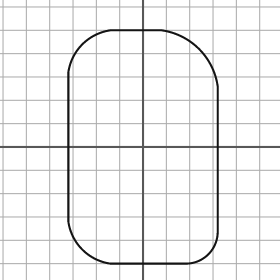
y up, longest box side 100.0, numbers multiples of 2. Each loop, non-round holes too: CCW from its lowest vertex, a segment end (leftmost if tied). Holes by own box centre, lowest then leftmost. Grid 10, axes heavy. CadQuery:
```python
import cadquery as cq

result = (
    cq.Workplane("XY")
    .moveTo(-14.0, -50.0)
    .lineTo(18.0, -50.0)
    .threePointArc((28.0, -46.0), (32.0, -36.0))
    .lineTo(32.0, 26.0)
    .threePointArc((24.0, 42.0), (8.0, 50.0))
    .lineTo(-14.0, 50.0)
    .threePointArc((-26.0, 44.0), (-32.0, 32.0))
    .lineTo(-32.0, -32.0)
    .threePointArc((-26.0, -44.0), (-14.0, -50.0))
    .close()
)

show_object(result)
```